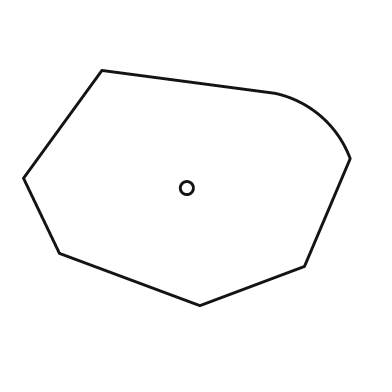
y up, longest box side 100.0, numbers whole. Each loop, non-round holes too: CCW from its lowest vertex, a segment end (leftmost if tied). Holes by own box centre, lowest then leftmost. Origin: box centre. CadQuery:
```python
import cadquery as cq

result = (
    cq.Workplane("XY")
    .moveTo(4.0, -36.0)
    .lineTo(36.0, -24.0)
    .lineTo(50.0, 9.0)
    .threePointArc((41.0, 22.0), (27.0, 29.0))
    .lineTo(-26.0, 36.0)
    .lineTo(-50.0, 3.0)
    .lineTo(-39.0, -20.0)
    .close()
    .moveTo(0.0, 0.0)
    .circle(2.0)
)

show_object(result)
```